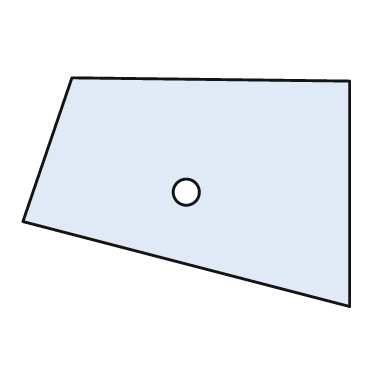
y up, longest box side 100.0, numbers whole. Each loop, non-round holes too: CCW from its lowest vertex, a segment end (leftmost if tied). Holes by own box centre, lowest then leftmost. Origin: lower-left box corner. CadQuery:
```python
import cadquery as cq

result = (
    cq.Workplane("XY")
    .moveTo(100.0, 0.0)
    .lineTo(100.0, 69.0)
    .lineTo(15.0, 70.0)
    .lineTo(0.0, 26.0)
    .close()
    .moveTo(50.0, 35.0)
    .circle(4.0)
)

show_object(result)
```